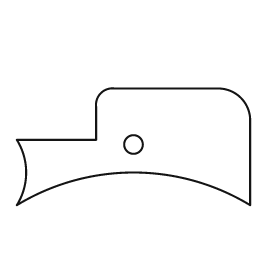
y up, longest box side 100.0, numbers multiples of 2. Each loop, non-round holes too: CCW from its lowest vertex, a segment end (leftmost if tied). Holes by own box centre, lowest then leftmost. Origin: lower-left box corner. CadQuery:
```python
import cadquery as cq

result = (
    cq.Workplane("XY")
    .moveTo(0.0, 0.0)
    .threePointArc((50.0, 14.0), (100.0, 0.0))
    .lineTo(100.0, 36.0)
    .threePointArc((96.0, 46.0), (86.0, 50.0))
    .lineTo(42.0, 50.0)
    .threePointArc((36.0, 48.0), (34.0, 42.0))
    .lineTo(34.0, 28.0)
    .lineTo(0.0, 28.0)
    .threePointArc((4.0, 14.0), (0.0, 0.0))
    .close()
    .moveTo(50.0, 26.0)
    .circle(4.0)
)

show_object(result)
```